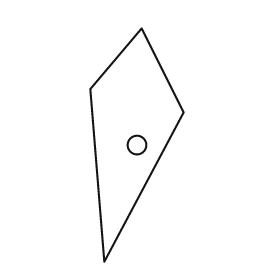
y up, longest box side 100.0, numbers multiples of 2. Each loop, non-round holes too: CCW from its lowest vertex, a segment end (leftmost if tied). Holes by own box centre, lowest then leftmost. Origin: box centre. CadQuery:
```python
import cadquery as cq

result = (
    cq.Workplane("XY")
    .moveTo(-14.0, -50.0)
    .lineTo(20.0, 14.0)
    .lineTo(2.0, 50.0)
    .lineTo(-20.0, 24.0)
    .close()
    .moveTo(0.0, 0.0)
    .circle(4.0)
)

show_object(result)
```